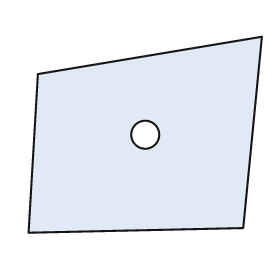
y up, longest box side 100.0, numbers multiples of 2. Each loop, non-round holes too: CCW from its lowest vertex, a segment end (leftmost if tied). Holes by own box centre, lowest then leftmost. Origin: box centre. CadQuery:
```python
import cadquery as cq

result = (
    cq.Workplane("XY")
    .moveTo(-50.0, -42.0)
    .lineTo(42.0, -40.0)
    .lineTo(50.0, 42.0)
    .lineTo(-46.0, 26.0)
    .close()
    .moveTo(0.0, 0.0)
    .circle(6.0)
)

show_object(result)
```